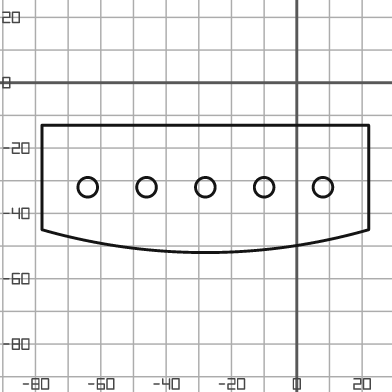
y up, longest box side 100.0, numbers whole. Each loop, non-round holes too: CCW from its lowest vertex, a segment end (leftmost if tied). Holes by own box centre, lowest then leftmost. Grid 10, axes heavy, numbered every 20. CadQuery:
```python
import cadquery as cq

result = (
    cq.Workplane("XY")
    .moveTo(-78.0, -45.0)
    .threePointArc((-28.0, -52.0), (22.0, -45.0))
    .lineTo(22.0, -13.0)
    .lineTo(-78.0, -13.0)
    .close()
    .moveTo(-64.0, -32.0)
    .circle(3.0)
    .moveTo(-46.0, -32.0)
    .circle(3.0)
    .moveTo(-28.0, -32.0)
    .circle(3.0)
    .moveTo(-10.0, -32.0)
    .circle(3.0)
    .moveTo(8.0, -32.0)
    .circle(3.0)
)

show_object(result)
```